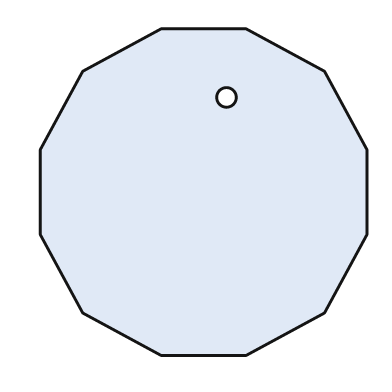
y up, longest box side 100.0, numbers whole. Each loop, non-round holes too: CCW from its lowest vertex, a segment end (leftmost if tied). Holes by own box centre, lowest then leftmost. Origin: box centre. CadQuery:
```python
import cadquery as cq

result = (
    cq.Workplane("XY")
    .moveTo(-13.0, -50.0)
    .lineTo(13.0, -50.0)
    .lineTo(37.0, -37.0)
    .lineTo(50.0, -13.0)
    .lineTo(50.0, 13.0)
    .lineTo(37.0, 37.0)
    .lineTo(13.0, 50.0)
    .lineTo(-13.0, 50.0)
    .lineTo(-37.0, 37.0)
    .lineTo(-50.0, 13.0)
    .lineTo(-50.0, -13.0)
    .lineTo(-37.0, -37.0)
    .close()
    .moveTo(7.0, 29.0)
    .circle(3.0)
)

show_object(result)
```